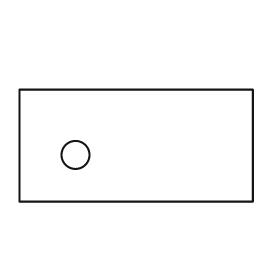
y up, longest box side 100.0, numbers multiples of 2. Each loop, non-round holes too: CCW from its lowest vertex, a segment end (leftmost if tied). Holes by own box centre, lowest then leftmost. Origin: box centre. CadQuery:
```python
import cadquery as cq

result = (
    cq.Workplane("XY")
    .moveTo(-50.0, -24.0)
    .lineTo(50.0, -24.0)
    .lineTo(50.0, 24.0)
    .lineTo(-50.0, 24.0)
    .close()
    .moveTo(-26.0, -4.0)
    .circle(6.0)
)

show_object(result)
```